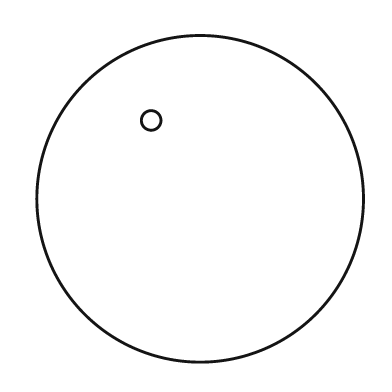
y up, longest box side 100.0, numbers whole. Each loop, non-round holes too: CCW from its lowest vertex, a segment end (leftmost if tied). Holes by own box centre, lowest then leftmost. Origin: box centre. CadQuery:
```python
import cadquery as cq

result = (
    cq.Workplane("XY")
    .moveTo(0.0, 0.0)
    .circle(50.0)
    .moveTo(-15.0, 24.0)
    .circle(3.0)
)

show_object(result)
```